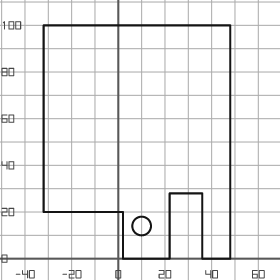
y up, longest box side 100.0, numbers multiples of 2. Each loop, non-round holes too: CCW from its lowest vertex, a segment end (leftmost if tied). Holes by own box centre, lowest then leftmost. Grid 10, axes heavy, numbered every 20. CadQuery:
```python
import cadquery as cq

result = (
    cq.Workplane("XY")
    .moveTo(2.0, 0.0)
    .lineTo(22.0, 0.0)
    .lineTo(22.0, 28.0)
    .lineTo(36.0, 28.0)
    .lineTo(36.0, 0.0)
    .lineTo(48.0, 0.0)
    .lineTo(48.0, 100.0)
    .lineTo(-32.0, 100.0)
    .lineTo(-32.0, 20.0)
    .lineTo(2.0, 20.0)
    .close()
    .moveTo(10.0, 14.0)
    .circle(4.0)
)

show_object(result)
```